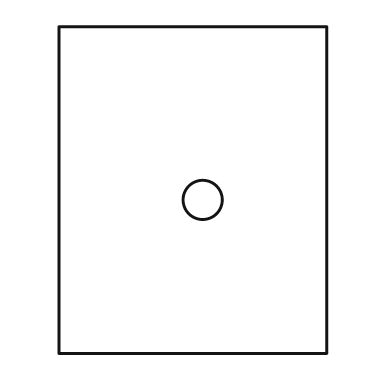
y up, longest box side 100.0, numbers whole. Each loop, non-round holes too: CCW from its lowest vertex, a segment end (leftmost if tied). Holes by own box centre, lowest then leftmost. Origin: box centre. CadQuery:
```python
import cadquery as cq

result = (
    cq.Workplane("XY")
    .moveTo(-41.0, -50.0)
    .lineTo(41.0, -50.0)
    .lineTo(41.0, 50.0)
    .lineTo(-41.0, 50.0)
    .close()
    .moveTo(3.0, -3.0)
    .circle(6.0)
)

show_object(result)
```